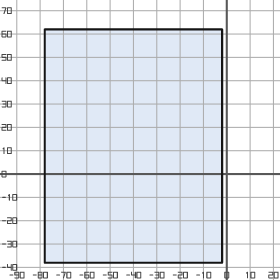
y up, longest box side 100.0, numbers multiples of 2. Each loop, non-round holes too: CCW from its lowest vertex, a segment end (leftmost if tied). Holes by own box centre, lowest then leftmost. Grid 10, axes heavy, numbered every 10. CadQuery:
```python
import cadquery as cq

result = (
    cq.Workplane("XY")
    .moveTo(-78.0, -38.0)
    .lineTo(-2.0, -38.0)
    .lineTo(-2.0, 62.0)
    .lineTo(-78.0, 62.0)
    .close()
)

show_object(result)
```